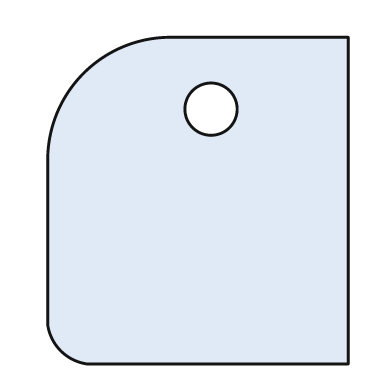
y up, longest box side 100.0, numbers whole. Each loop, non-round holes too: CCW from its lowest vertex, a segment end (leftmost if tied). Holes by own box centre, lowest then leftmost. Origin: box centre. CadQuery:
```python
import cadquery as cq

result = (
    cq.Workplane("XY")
    .moveTo(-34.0, -50.0)
    .lineTo(46.0, -50.0)
    .lineTo(46.0, 50.0)
    .lineTo(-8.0, 50.0)
    .threePointArc((-35.0, 39.0), (-46.0, 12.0))
    .lineTo(-46.0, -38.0)
    .threePointArc((-42.0, -46.0), (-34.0, -50.0))
    .close()
    .moveTo(4.0, 28.0)
    .circle(8.0)
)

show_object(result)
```